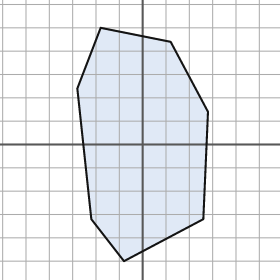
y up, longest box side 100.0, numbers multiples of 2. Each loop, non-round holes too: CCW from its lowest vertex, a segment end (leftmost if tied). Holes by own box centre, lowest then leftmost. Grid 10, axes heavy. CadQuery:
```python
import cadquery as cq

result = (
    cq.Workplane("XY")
    .moveTo(-8.0, -50.0)
    .lineTo(26.0, -32.0)
    .lineTo(28.0, 14.0)
    .lineTo(12.0, 44.0)
    .lineTo(-18.0, 50.0)
    .lineTo(-28.0, 24.0)
    .lineTo(-22.0, -32.0)
    .close()
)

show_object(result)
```